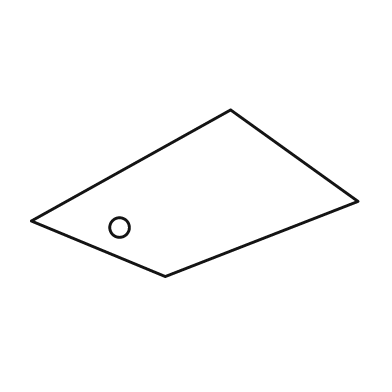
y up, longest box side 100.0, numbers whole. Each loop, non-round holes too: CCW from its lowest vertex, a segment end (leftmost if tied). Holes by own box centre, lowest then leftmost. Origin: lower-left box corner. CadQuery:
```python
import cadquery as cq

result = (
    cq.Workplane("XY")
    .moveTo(41.0, 0.0)
    .lineTo(100.0, 23.0)
    .lineTo(61.0, 51.0)
    .lineTo(0.0, 17.0)
    .close()
    .moveTo(27.0, 15.0)
    .circle(3.0)
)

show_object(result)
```